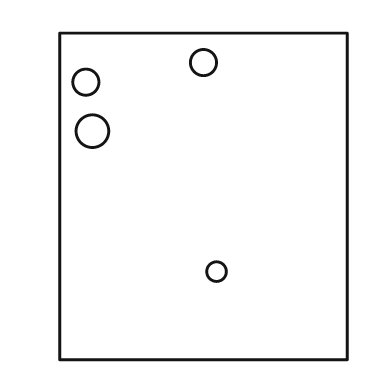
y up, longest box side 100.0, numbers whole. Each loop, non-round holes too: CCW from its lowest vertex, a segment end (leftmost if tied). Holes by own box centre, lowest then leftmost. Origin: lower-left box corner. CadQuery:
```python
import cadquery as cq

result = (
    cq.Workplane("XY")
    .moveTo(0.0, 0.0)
    .lineTo(88.0, 0.0)
    .lineTo(88.0, 100.0)
    .lineTo(0.0, 100.0)
    .close()
    .moveTo(48.0, 27.0)
    .circle(3.0)
    .moveTo(10.0, 70.0)
    .circle(5.0)
    .moveTo(8.0, 85.0)
    .circle(4.0)
    .moveTo(44.0, 91.0)
    .circle(4.0)
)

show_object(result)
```